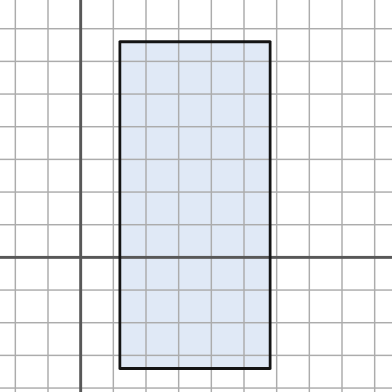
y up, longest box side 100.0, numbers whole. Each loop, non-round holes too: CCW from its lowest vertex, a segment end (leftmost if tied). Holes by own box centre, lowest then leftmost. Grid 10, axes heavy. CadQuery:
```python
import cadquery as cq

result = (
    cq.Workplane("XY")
    .moveTo(12.0, -34.0)
    .lineTo(58.0, -34.0)
    .lineTo(58.0, 66.0)
    .lineTo(12.0, 66.0)
    .close()
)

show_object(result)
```